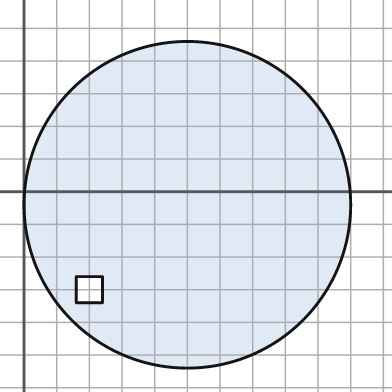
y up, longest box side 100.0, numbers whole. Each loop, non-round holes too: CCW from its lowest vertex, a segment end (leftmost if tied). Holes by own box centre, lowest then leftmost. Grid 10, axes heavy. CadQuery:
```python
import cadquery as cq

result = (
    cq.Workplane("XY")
    .moveTo(50.0, -4.0)
    .circle(50.0)
    .moveTo(16.0, -34.0)
    .lineTo(24.0, -34.0)
    .lineTo(24.0, -26.0)
    .lineTo(16.0, -26.0)
    .close()
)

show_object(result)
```